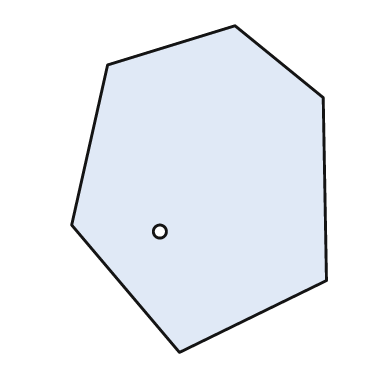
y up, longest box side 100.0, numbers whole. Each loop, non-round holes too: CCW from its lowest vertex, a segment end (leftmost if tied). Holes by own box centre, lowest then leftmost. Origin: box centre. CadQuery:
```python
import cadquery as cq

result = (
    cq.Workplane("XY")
    .moveTo(-6.0, -50.0)
    .lineTo(39.0, -28.0)
    .lineTo(38.0, 28.0)
    .lineTo(11.0, 50.0)
    .lineTo(-28.0, 38.0)
    .lineTo(-39.0, -11.0)
    .close()
    .moveTo(-12.0, -13.0)
    .circle(2.0)
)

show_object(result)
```